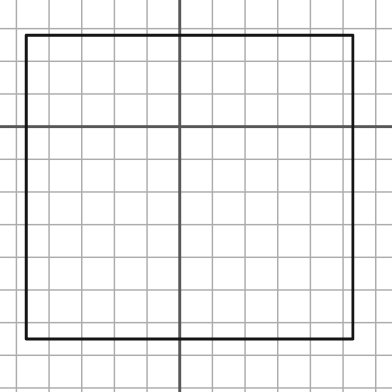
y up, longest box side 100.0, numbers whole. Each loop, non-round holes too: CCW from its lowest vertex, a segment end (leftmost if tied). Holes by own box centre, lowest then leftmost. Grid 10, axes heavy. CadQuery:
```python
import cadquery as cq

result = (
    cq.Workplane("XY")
    .moveTo(-47.0, -65.0)
    .lineTo(53.0, -65.0)
    .lineTo(53.0, 28.0)
    .lineTo(-47.0, 28.0)
    .close()
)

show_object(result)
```